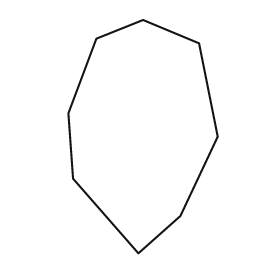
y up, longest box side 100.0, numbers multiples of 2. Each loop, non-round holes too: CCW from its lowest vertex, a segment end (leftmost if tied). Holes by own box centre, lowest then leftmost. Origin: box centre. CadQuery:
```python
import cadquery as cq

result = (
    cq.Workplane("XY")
    .moveTo(-2.0, -50.0)
    .lineTo(16.0, -34.0)
    .lineTo(32.0, 0.0)
    .lineTo(24.0, 40.0)
    .lineTo(0.0, 50.0)
    .lineTo(-20.0, 42.0)
    .lineTo(-32.0, 10.0)
    .lineTo(-30.0, -18.0)
    .close()
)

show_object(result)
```